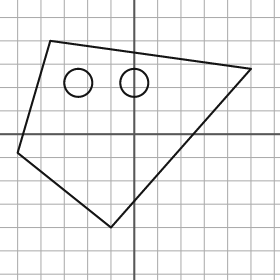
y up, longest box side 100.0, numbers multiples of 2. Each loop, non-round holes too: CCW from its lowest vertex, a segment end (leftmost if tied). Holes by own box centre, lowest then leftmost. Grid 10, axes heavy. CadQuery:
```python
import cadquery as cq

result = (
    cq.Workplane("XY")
    .moveTo(-10.0, -40.0)
    .lineTo(50.0, 28.0)
    .lineTo(-36.0, 40.0)
    .lineTo(-50.0, -8.0)
    .close()
    .moveTo(-24.0, 22.0)
    .circle(6.0)
    .moveTo(0.0, 22.0)
    .circle(6.0)
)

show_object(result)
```